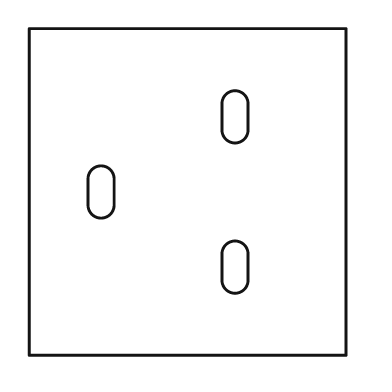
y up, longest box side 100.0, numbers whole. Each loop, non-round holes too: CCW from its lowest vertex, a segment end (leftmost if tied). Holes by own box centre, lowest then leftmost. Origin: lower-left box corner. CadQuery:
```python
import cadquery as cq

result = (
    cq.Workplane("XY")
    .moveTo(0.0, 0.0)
    .lineTo(97.0, 0.0)
    .lineTo(97.0, 100.0)
    .lineTo(0.0, 100.0)
    .close()
    .moveTo(59.0, 23.0)
    .threePointArc((63.0, 19.0), (67.0, 23.0))
    .lineTo(67.0, 31.0)
    .threePointArc((63.0, 35.0), (59.0, 31.0))
    .close()
    .moveTo(18.0, 46.0)
    .threePointArc((22.0, 42.0), (26.0, 46.0))
    .lineTo(26.0, 54.0)
    .threePointArc((22.0, 58.0), (18.0, 54.0))
    .close()
    .moveTo(59.0, 69.0)
    .threePointArc((63.0, 65.0), (67.0, 69.0))
    .lineTo(67.0, 77.0)
    .threePointArc((63.0, 81.0), (59.0, 77.0))
    .close()
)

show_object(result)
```